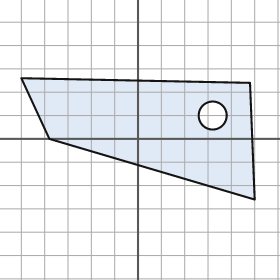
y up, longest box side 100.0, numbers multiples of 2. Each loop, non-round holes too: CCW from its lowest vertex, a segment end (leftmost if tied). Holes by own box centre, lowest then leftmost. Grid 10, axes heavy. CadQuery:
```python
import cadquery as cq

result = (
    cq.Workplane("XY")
    .moveTo(50.0, -26.0)
    .lineTo(48.0, 24.0)
    .lineTo(-50.0, 26.0)
    .lineTo(-38.0, 0.0)
    .close()
    .moveTo(32.0, 10.0)
    .circle(6.0)
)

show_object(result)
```